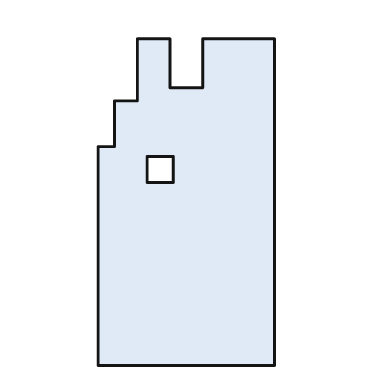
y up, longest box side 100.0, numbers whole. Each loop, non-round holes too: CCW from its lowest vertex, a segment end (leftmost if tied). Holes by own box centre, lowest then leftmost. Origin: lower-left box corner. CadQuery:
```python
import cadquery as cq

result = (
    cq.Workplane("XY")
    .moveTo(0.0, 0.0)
    .lineTo(54.0, 0.0)
    .lineTo(54.0, 100.0)
    .lineTo(32.0, 100.0)
    .lineTo(32.0, 85.0)
    .lineTo(22.0, 85.0)
    .lineTo(22.0, 100.0)
    .lineTo(12.0, 100.0)
    .lineTo(12.0, 81.0)
    .lineTo(5.0, 81.0)
    .lineTo(5.0, 67.0)
    .lineTo(0.0, 67.0)
    .close()
    .moveTo(15.0, 56.0)
    .lineTo(23.0, 56.0)
    .lineTo(23.0, 64.0)
    .lineTo(15.0, 64.0)
    .close()
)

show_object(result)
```